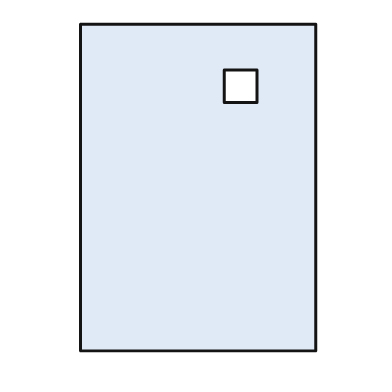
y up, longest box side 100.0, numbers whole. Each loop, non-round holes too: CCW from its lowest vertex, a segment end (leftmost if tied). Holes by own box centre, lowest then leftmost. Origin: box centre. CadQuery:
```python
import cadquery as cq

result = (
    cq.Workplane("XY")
    .moveTo(-36.0, -50.0)
    .lineTo(36.0, -50.0)
    .lineTo(36.0, 50.0)
    .lineTo(-36.0, 50.0)
    .close()
    .moveTo(8.0, 26.0)
    .lineTo(18.0, 26.0)
    .lineTo(18.0, 36.0)
    .lineTo(8.0, 36.0)
    .close()
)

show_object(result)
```